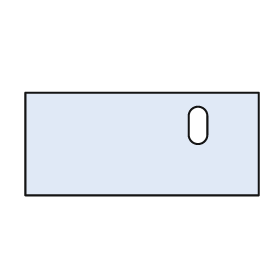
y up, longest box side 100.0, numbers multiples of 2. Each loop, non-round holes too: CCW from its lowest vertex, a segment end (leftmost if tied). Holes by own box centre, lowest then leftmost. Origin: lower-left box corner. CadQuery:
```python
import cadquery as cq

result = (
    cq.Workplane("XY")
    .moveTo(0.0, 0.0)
    .lineTo(100.0, 0.0)
    .lineTo(100.0, 44.0)
    .lineTo(0.0, 44.0)
    .close()
    .moveTo(70.0, 26.0)
    .threePointArc((74.0, 22.0), (78.0, 26.0))
    .lineTo(78.0, 34.0)
    .threePointArc((74.0, 38.0), (70.0, 34.0))
    .close()
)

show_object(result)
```